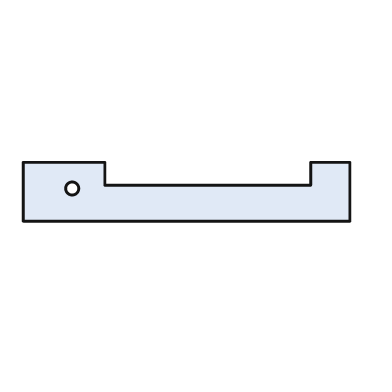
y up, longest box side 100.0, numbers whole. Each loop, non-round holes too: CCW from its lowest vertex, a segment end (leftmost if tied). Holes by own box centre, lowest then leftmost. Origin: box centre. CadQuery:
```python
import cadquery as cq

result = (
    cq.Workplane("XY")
    .moveTo(-50.0, -9.0)
    .lineTo(50.0, -9.0)
    .lineTo(50.0, 9.0)
    .lineTo(38.0, 9.0)
    .lineTo(38.0, 2.0)
    .lineTo(-25.0, 2.0)
    .lineTo(-25.0, 9.0)
    .lineTo(-50.0, 9.0)
    .close()
    .moveTo(-35.0, 1.0)
    .circle(2.0)
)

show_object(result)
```